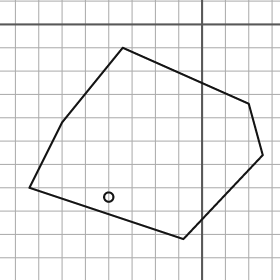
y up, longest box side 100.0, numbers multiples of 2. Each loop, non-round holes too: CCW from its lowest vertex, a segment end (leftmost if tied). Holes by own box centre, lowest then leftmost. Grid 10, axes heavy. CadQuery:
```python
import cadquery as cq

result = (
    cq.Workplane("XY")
    .moveTo(-8.0, -92.0)
    .lineTo(26.0, -56.0)
    .lineTo(20.0, -34.0)
    .lineTo(-34.0, -10.0)
    .lineTo(-60.0, -42.0)
    .lineTo(-74.0, -70.0)
    .close()
    .moveTo(-40.0, -74.0)
    .circle(2.0)
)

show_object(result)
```